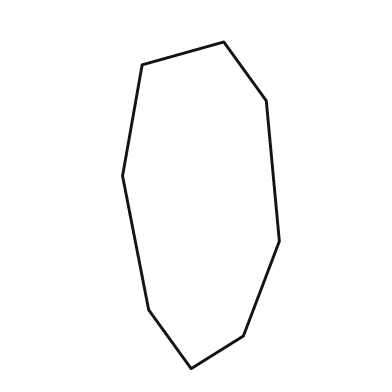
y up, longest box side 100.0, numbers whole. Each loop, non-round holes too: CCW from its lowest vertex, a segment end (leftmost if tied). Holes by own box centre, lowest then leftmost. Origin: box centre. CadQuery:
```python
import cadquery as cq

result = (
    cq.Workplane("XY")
    .moveTo(-3.0, -50.0)
    .lineTo(13.0, -40.0)
    .lineTo(24.0, -11.0)
    .lineTo(20.0, 32.0)
    .lineTo(7.0, 50.0)
    .lineTo(-18.0, 43.0)
    .lineTo(-24.0, 9.0)
    .lineTo(-16.0, -32.0)
    .close()
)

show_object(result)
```